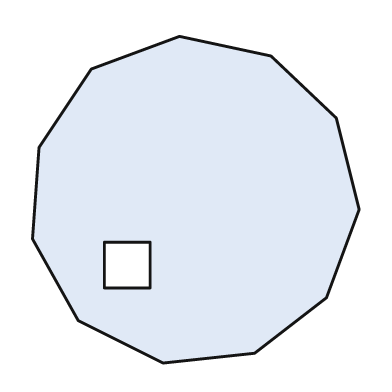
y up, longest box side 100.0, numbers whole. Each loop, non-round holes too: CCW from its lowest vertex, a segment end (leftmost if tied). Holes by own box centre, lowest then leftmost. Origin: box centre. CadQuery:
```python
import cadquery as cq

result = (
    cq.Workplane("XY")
    .moveTo(-10.0, -50.0)
    .lineTo(18.0, -47.0)
    .lineTo(40.0, -30.0)
    .lineTo(50.0, -3.0)
    .lineTo(43.0, 25.0)
    .lineTo(23.0, 44.0)
    .lineTo(-5.0, 50.0)
    .lineTo(-32.0, 40.0)
    .lineTo(-48.0, 16.0)
    .lineTo(-50.0, -12.0)
    .lineTo(-36.0, -37.0)
    .close()
    .moveTo(-28.0, -27.0)
    .lineTo(-14.0, -27.0)
    .lineTo(-14.0, -13.0)
    .lineTo(-28.0, -13.0)
    .close()
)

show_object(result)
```